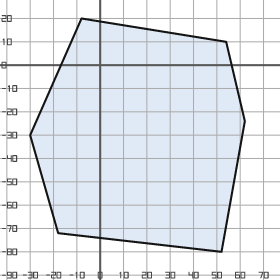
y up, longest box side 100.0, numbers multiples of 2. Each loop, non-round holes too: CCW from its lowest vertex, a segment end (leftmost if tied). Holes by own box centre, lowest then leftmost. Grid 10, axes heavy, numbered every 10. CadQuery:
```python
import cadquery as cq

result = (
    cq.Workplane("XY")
    .moveTo(52.0, -80.0)
    .lineTo(62.0, -24.0)
    .lineTo(54.0, 10.0)
    .lineTo(-8.0, 20.0)
    .lineTo(-30.0, -30.0)
    .lineTo(-18.0, -72.0)
    .close()
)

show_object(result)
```